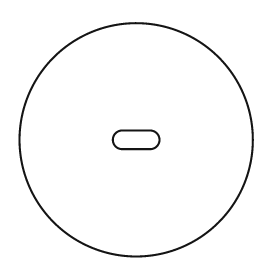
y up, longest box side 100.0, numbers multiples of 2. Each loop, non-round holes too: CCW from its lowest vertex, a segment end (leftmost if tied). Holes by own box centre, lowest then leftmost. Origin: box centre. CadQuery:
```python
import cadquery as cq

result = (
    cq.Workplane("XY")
    .moveTo(0.0, 0.0)
    .circle(50.0)
    .moveTo(-6.0, -4.0)
    .lineTo(6.0, -4.0)
    .threePointArc((10.0, 0.0), (6.0, 4.0))
    .lineTo(-6.0, 4.0)
    .threePointArc((-10.0, 0.0), (-6.0, -4.0))
    .close()
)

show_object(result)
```